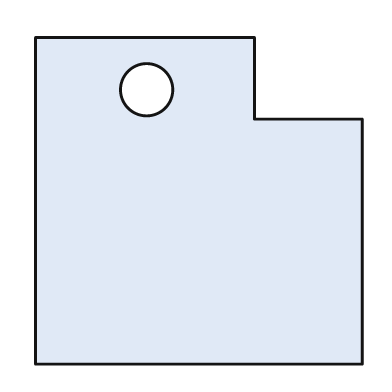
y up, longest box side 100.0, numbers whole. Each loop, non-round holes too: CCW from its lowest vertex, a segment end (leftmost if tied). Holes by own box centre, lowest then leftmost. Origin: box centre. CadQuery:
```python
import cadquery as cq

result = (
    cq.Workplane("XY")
    .moveTo(-50.0, -50.0)
    .lineTo(50.0, -50.0)
    .lineTo(50.0, 25.0)
    .lineTo(17.0, 25.0)
    .lineTo(17.0, 50.0)
    .lineTo(-50.0, 50.0)
    .close()
    .moveTo(-16.0, 34.0)
    .circle(8.0)
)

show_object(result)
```